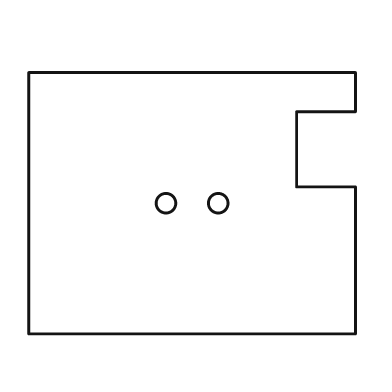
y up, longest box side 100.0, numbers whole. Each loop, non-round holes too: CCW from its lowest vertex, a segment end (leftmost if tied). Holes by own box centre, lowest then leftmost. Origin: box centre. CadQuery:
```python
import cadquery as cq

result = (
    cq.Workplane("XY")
    .moveTo(-50.0, -40.0)
    .lineTo(50.0, -40.0)
    .lineTo(50.0, 5.0)
    .lineTo(32.0, 5.0)
    .lineTo(32.0, 28.0)
    .lineTo(50.0, 28.0)
    .lineTo(50.0, 40.0)
    .lineTo(-50.0, 40.0)
    .close()
    .moveTo(-8.0, 0.0)
    .circle(3.0)
    .moveTo(8.0, 0.0)
    .circle(3.0)
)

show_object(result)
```